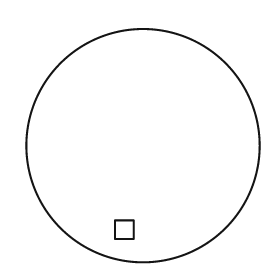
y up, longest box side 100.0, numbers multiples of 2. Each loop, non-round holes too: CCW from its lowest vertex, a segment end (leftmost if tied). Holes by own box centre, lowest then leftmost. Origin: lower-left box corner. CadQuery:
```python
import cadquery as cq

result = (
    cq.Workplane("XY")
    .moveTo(50.0, 50.0)
    .circle(50.0)
    .moveTo(38.0, 10.0)
    .lineTo(46.0, 10.0)
    .lineTo(46.0, 18.0)
    .lineTo(38.0, 18.0)
    .close()
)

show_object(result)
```